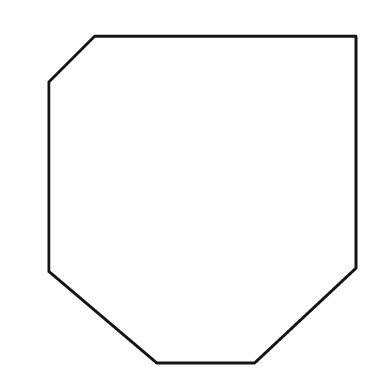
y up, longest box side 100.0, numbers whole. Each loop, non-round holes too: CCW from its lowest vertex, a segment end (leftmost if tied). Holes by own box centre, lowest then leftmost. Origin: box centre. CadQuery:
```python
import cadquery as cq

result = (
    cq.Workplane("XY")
    .moveTo(-14.0, -50.0)
    .lineTo(16.0, -50.0)
    .lineTo(47.0, -21.0)
    .lineTo(47.0, 50.0)
    .lineTo(-33.0, 50.0)
    .lineTo(-47.0, 36.0)
    .lineTo(-47.0, -22.0)
    .close()
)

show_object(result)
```